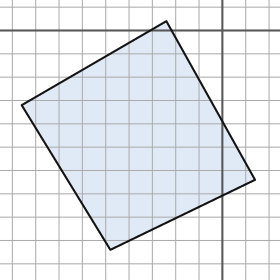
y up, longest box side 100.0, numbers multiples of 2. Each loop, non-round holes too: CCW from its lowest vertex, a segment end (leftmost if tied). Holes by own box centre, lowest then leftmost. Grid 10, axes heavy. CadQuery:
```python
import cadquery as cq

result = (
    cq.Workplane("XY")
    .moveTo(-48.0, -94.0)
    .lineTo(14.0, -64.0)
    .lineTo(-24.0, 4.0)
    .lineTo(-86.0, -32.0)
    .close()
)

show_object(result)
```